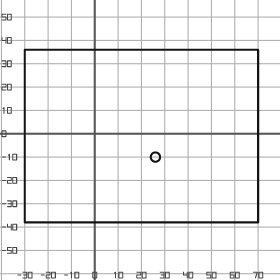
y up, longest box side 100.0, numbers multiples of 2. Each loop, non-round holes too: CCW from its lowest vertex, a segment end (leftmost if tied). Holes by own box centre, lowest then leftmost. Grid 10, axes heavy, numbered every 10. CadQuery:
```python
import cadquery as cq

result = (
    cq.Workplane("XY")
    .moveTo(-30.0, -38.0)
    .lineTo(70.0, -38.0)
    .lineTo(70.0, 36.0)
    .lineTo(-30.0, 36.0)
    .close()
    .moveTo(26.0, -10.0)
    .circle(2.0)
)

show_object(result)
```